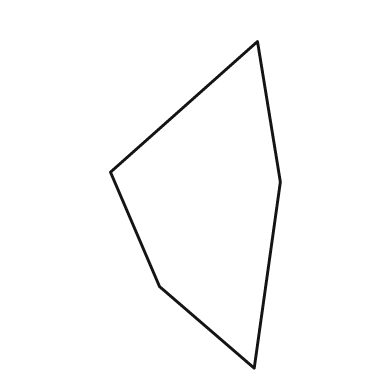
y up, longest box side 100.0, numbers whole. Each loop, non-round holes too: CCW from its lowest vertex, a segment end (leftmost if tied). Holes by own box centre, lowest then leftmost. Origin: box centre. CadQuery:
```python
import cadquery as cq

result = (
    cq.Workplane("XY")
    .moveTo(18.0, -50.0)
    .lineTo(26.0, 7.0)
    .lineTo(19.0, 50.0)
    .lineTo(-26.0, 10.0)
    .lineTo(-11.0, -25.0)
    .close()
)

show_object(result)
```